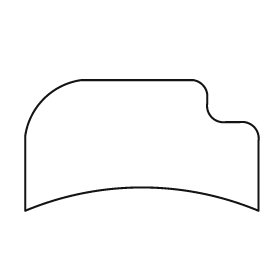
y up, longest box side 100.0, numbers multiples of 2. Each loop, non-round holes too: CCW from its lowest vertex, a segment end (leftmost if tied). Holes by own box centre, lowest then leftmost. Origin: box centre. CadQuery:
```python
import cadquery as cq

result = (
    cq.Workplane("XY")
    .moveTo(-50.0, -28.0)
    .threePointArc((0.0, -18.0), (50.0, -28.0))
    .lineTo(50.0, 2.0)
    .threePointArc((48.0, 8.0), (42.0, 10.0))
    .lineTo(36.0, 10.0)
    .threePointArc((30.0, 12.0), (28.0, 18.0))
    .lineTo(28.0, 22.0)
    .threePointArc((26.0, 26.0), (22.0, 28.0))
    .lineTo(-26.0, 28.0)
    .threePointArc((-42.0, 20.0), (-50.0, 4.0))
    .close()
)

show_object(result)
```